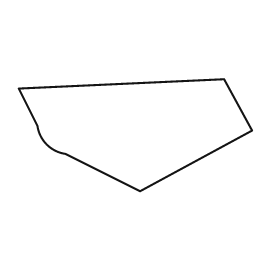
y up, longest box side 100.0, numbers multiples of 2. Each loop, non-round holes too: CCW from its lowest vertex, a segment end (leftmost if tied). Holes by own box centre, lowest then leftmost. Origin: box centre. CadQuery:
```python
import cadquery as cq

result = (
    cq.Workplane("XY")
    .moveTo(2.0, -24.0)
    .lineTo(50.0, 2.0)
    .lineTo(38.0, 24.0)
    .lineTo(-50.0, 20.0)
    .lineTo(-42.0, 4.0)
    .threePointArc((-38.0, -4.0), (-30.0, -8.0))
    .close()
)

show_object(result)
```